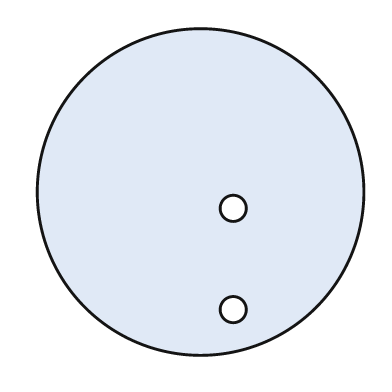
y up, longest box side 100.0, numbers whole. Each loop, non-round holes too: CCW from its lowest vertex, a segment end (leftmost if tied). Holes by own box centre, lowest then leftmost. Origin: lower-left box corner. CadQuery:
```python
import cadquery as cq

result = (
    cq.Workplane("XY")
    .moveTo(50.0, 50.0)
    .circle(50.0)
    .moveTo(60.0, 14.0)
    .circle(4.0)
    .moveTo(60.0, 45.0)
    .circle(4.0)
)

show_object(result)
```